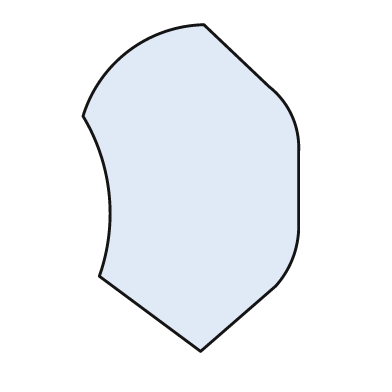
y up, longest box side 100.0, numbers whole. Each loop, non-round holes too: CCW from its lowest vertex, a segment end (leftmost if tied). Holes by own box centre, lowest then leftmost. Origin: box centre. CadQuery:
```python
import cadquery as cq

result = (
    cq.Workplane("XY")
    .moveTo(3.0, -50.0)
    .lineTo(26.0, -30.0)
    .threePointArc((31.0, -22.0), (33.0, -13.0))
    .lineTo(33.0, 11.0)
    .threePointArc((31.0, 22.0), (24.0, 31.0))
    .lineTo(4.0, 50.0)
    .threePointArc((-19.0, 42.0), (-33.0, 22.0))
    .threePointArc((-25.0, -2.0), (-28.0, -27.0))
    .close()
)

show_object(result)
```